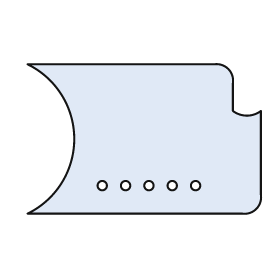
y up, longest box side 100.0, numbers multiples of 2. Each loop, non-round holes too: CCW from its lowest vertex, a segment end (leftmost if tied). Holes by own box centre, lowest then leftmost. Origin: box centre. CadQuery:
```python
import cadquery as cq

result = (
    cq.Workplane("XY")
    .moveTo(-50.0, -32.0)
    .lineTo(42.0, -32.0)
    .threePointArc((48.0, -30.0), (50.0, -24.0))
    .lineTo(50.0, 12.0)
    .threePointArc((44.0, 10.0), (38.0, 12.0))
    .lineTo(38.0, 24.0)
    .threePointArc((36.0, 30.0), (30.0, 32.0))
    .lineTo(-50.0, 32.0)
    .threePointArc((-30.0, 0.0), (-50.0, -32.0))
    .close()
    .moveTo(-18.0, -20.0)
    .circle(2.0)
    .moveTo(-8.0, -20.0)
    .circle(2.0)
    .moveTo(2.0, -20.0)
    .circle(2.0)
    .moveTo(12.0, -20.0)
    .circle(2.0)
    .moveTo(22.0, -20.0)
    .circle(2.0)
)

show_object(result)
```